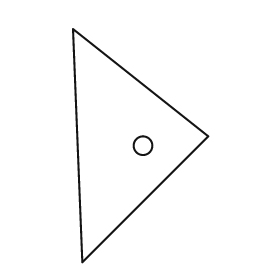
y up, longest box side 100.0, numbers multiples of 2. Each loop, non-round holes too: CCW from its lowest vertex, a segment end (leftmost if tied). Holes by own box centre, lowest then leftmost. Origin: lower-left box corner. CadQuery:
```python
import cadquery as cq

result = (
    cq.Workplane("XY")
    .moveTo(4.0, 0.0)
    .lineTo(58.0, 54.0)
    .lineTo(0.0, 100.0)
    .close()
    .moveTo(30.0, 50.0)
    .circle(4.0)
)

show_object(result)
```